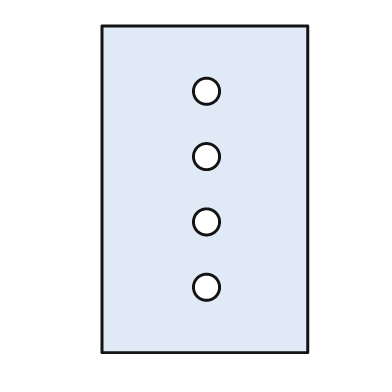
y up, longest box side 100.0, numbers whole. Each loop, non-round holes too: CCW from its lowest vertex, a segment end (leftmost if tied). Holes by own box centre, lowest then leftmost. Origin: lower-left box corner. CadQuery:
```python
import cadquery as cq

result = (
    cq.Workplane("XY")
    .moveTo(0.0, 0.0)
    .lineTo(63.0, 0.0)
    .lineTo(63.0, 100.0)
    .lineTo(0.0, 100.0)
    .close()
    .moveTo(32.0, 20.0)
    .circle(4.0)
    .moveTo(32.0, 40.0)
    .circle(4.0)
    .moveTo(32.0, 60.0)
    .circle(4.0)
    .moveTo(32.0, 80.0)
    .circle(4.0)
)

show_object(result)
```